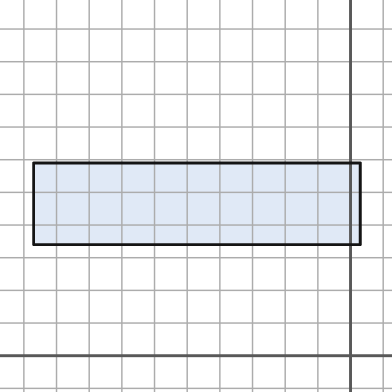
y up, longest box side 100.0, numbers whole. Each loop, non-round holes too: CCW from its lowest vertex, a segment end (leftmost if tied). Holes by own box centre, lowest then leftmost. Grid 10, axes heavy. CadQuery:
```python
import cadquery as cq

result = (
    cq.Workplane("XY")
    .moveTo(-97.0, 34.0)
    .lineTo(3.0, 34.0)
    .lineTo(3.0, 59.0)
    .lineTo(-97.0, 59.0)
    .close()
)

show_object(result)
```